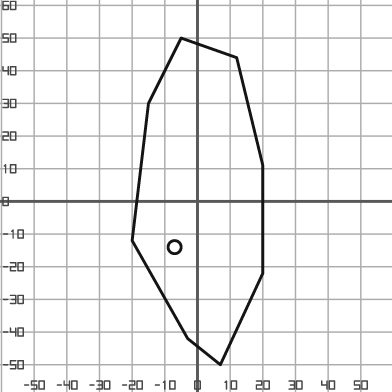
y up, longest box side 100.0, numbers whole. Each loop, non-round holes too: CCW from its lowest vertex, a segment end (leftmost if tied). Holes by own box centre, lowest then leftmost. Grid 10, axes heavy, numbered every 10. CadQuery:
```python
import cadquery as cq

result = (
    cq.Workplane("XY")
    .moveTo(7.0, -50.0)
    .lineTo(20.0, -22.0)
    .lineTo(20.0, 11.0)
    .lineTo(12.0, 44.0)
    .lineTo(-5.0, 50.0)
    .lineTo(-15.0, 30.0)
    .lineTo(-20.0, -12.0)
    .lineTo(-3.0, -42.0)
    .close()
    .moveTo(-7.0, -14.0)
    .circle(2.0)
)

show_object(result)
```